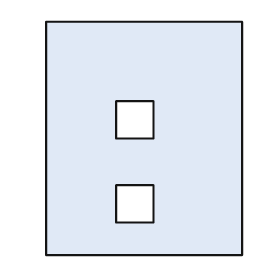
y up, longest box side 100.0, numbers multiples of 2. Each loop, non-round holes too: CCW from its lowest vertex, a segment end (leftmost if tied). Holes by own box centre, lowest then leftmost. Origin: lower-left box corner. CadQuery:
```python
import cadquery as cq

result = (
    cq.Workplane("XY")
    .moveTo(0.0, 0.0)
    .lineTo(84.0, 0.0)
    .lineTo(84.0, 100.0)
    .lineTo(0.0, 100.0)
    .close()
    .moveTo(30.0, 14.0)
    .lineTo(46.0, 14.0)
    .lineTo(46.0, 30.0)
    .lineTo(30.0, 30.0)
    .close()
    .moveTo(30.0, 50.0)
    .lineTo(46.0, 50.0)
    .lineTo(46.0, 66.0)
    .lineTo(30.0, 66.0)
    .close()
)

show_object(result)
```